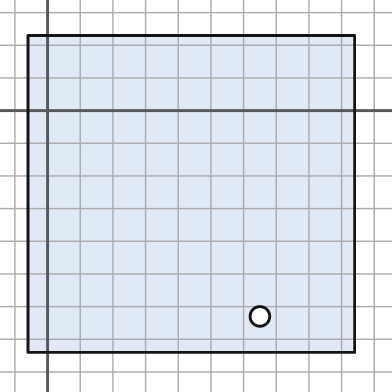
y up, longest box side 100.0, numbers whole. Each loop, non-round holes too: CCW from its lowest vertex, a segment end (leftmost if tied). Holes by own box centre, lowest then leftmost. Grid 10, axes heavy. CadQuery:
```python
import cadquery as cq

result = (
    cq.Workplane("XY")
    .moveTo(-6.0, -74.0)
    .lineTo(94.0, -74.0)
    .lineTo(94.0, 23.0)
    .lineTo(-6.0, 23.0)
    .close()
    .moveTo(65.0, -63.0)
    .circle(3.0)
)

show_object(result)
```